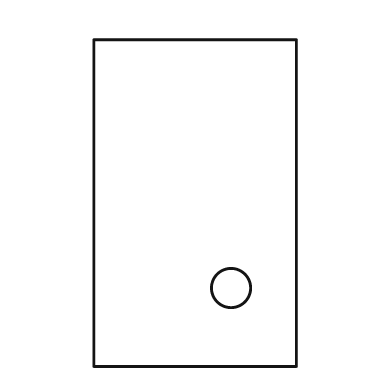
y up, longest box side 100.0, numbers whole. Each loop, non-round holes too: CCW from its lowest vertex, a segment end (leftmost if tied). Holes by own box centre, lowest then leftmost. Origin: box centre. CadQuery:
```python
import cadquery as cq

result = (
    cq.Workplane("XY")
    .moveTo(-31.0, -50.0)
    .lineTo(31.0, -50.0)
    .lineTo(31.0, 50.0)
    .lineTo(-31.0, 50.0)
    .close()
    .moveTo(11.0, -26.0)
    .circle(6.0)
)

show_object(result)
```